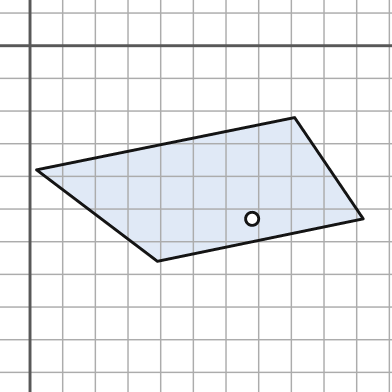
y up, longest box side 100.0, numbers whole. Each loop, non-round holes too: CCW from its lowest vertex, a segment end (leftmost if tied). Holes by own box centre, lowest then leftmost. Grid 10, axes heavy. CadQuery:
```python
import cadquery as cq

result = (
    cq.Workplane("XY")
    .moveTo(39.0, -66.0)
    .lineTo(102.0, -53.0)
    .lineTo(81.0, -22.0)
    .lineTo(2.0, -38.0)
    .close()
    .moveTo(68.0, -53.0)
    .circle(2.0)
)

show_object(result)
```